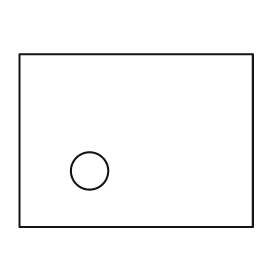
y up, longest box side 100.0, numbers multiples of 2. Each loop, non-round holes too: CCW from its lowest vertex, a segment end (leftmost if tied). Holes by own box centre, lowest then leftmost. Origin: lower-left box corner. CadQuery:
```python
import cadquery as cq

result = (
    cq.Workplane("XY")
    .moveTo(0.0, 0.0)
    .lineTo(100.0, 0.0)
    .lineTo(100.0, 74.0)
    .lineTo(0.0, 74.0)
    .close()
    .moveTo(30.0, 24.0)
    .circle(8.0)
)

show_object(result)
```